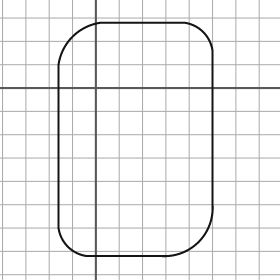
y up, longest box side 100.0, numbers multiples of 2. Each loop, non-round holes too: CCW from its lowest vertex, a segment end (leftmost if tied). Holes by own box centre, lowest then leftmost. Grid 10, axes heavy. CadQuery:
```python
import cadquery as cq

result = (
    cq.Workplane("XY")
    .moveTo(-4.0, -72.0)
    .lineTo(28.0, -72.0)
    .threePointArc((44.0, -66.0), (50.0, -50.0))
    .lineTo(50.0, 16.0)
    .threePointArc((46.0, 24.0), (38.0, 28.0))
    .lineTo(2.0, 28.0)
    .threePointArc((-10.0, 22.0), (-16.0, 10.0))
    .lineTo(-16.0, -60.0)
    .threePointArc((-12.0, -68.0), (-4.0, -72.0))
    .close()
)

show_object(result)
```